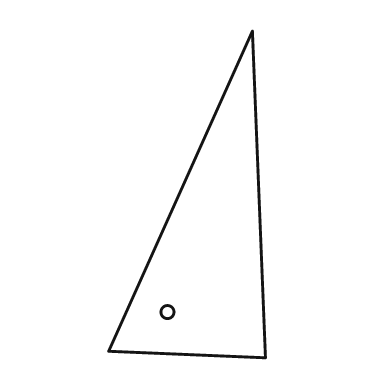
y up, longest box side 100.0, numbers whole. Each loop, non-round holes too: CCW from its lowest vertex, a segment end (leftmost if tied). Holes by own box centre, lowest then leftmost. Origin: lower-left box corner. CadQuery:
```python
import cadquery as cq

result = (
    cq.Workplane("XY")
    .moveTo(48.0, 0.0)
    .lineTo(44.0, 100.0)
    .lineTo(0.0, 2.0)
    .close()
    .moveTo(18.0, 14.0)
    .circle(2.0)
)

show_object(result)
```